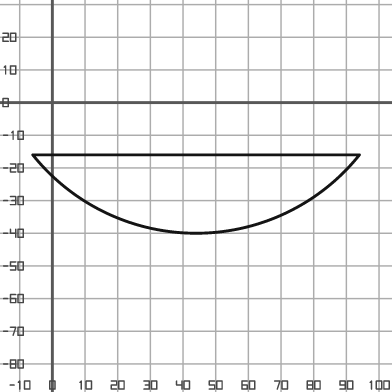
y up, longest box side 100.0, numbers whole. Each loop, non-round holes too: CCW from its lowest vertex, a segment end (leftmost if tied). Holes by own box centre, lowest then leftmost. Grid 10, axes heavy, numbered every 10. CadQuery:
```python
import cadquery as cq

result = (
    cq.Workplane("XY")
    .moveTo(-6.0, -16.0)
    .threePointArc((44.0, -40.0), (94.0, -16.0))
    .close()
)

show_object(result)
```